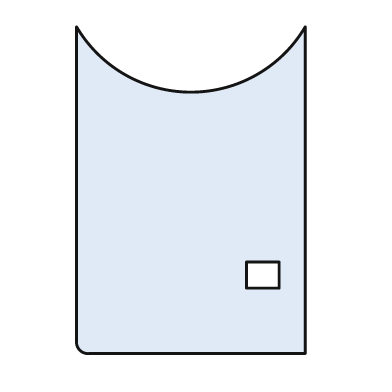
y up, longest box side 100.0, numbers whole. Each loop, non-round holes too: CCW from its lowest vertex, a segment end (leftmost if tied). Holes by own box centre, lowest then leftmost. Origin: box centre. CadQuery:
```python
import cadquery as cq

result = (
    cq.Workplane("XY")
    .moveTo(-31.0, -50.0)
    .lineTo(35.0, -50.0)
    .lineTo(35.0, 50.0)
    .threePointArc((0.0, 30.0), (-35.0, 50.0))
    .lineTo(-35.0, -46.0)
    .threePointArc((-34.0, -49.0), (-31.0, -50.0))
    .close()
    .moveTo(17.0, -30.0)
    .lineTo(27.0, -30.0)
    .lineTo(27.0, -22.0)
    .lineTo(17.0, -22.0)
    .close()
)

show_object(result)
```